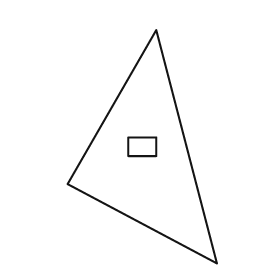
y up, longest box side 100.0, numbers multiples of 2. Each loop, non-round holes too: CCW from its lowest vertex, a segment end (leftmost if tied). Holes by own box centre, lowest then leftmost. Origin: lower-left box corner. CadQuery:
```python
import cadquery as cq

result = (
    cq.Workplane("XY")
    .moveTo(64.0, 0.0)
    .lineTo(38.0, 100.0)
    .lineTo(0.0, 34.0)
    .close()
    .moveTo(26.0, 46.0)
    .lineTo(38.0, 46.0)
    .lineTo(38.0, 54.0)
    .lineTo(26.0, 54.0)
    .close()
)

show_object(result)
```